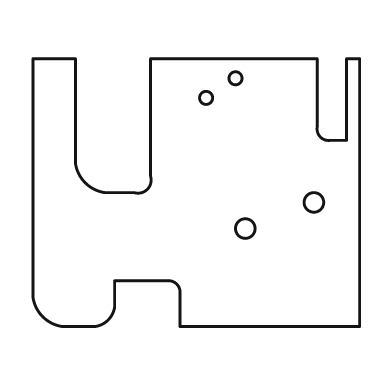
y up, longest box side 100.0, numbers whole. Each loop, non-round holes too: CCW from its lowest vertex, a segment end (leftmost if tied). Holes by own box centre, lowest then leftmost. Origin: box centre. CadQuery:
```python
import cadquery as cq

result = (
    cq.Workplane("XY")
    .moveTo(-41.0, -41.0)
    .lineTo(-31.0, -41.0)
    .threePointArc((-27.0, -39.0), (-25.0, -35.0))
    .lineTo(-25.0, -27.0)
    .lineTo(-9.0, -27.0)
    .threePointArc((-6.0, -28.0), (-5.0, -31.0))
    .lineTo(-5.0, -41.0)
    .lineTo(50.0, -41.0)
    .lineTo(50.0, 41.0)
    .lineTo(46.0, 41.0)
    .lineTo(46.0, 16.0)
    .lineTo(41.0, 16.0)
    .threePointArc((38.0, 17.0), (37.0, 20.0))
    .lineTo(37.0, 41.0)
    .lineTo(-14.0, 41.0)
    .lineTo(-14.0, 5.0)
    .threePointArc((-15.0, 1.0), (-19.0, 0.0))
    .lineTo(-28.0, 0.0)
    .threePointArc((-34.0, 3.0), (-37.0, 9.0))
    .lineTo(-37.0, 41.0)
    .lineTo(-50.0, 41.0)
    .lineTo(-50.0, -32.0)
    .threePointArc((-47.0, -38.0), (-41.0, -41.0))
    .close()
    .moveTo(15.0, -11.0)
    .circle(3.0)
    .moveTo(36.0, -3.0)
    .circle(3.0)
    .moveTo(3.0, 29.0)
    .circle(2.0)
    .moveTo(12.0, 35.0)
    .circle(2.0)
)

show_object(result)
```